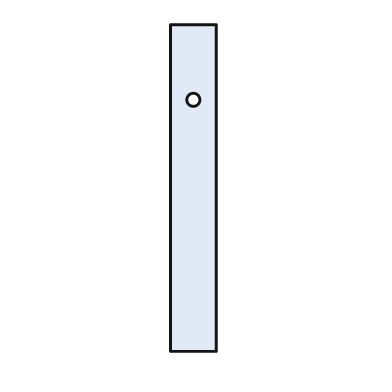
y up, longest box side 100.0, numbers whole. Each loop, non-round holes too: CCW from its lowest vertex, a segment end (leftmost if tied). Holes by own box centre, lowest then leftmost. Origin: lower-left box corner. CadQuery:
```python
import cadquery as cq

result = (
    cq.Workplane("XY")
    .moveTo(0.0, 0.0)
    .lineTo(14.0, 0.0)
    .lineTo(14.0, 100.0)
    .lineTo(0.0, 100.0)
    .close()
    .moveTo(7.0, 77.0)
    .circle(2.0)
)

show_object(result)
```